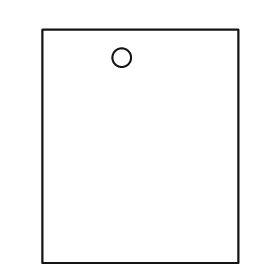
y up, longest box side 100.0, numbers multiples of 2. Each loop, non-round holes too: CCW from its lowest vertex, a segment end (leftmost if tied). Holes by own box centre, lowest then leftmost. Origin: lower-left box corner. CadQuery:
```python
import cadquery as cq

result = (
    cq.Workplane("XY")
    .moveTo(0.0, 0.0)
    .lineTo(84.0, 0.0)
    .lineTo(84.0, 100.0)
    .lineTo(0.0, 100.0)
    .close()
    .moveTo(34.0, 88.0)
    .circle(4.0)
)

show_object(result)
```